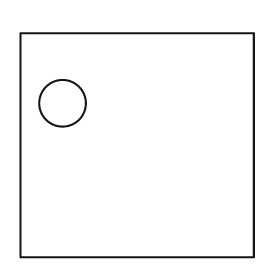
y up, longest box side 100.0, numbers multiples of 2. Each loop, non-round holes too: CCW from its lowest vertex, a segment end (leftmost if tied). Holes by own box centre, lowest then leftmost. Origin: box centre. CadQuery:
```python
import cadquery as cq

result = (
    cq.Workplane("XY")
    .moveTo(-50.0, -48.0)
    .lineTo(50.0, -48.0)
    .lineTo(50.0, 48.0)
    .lineTo(-50.0, 48.0)
    .close()
    .moveTo(-32.0, 18.0)
    .circle(10.0)
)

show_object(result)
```